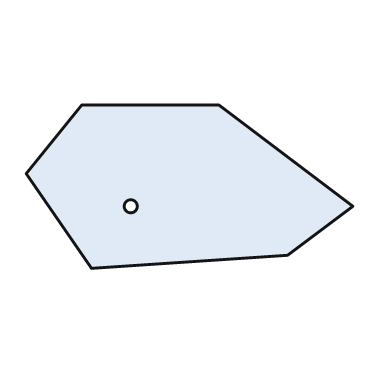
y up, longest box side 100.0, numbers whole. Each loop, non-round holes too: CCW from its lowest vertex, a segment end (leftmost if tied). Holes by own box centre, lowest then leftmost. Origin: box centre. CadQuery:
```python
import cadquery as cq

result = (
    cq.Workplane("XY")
    .moveTo(-30.0, -25.0)
    .lineTo(30.0, -21.0)
    .lineTo(50.0, -6.0)
    .lineTo(9.0, 25.0)
    .lineTo(-33.0, 25.0)
    .lineTo(-50.0, 4.0)
    .close()
    .moveTo(-18.0, -6.0)
    .circle(2.0)
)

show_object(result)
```